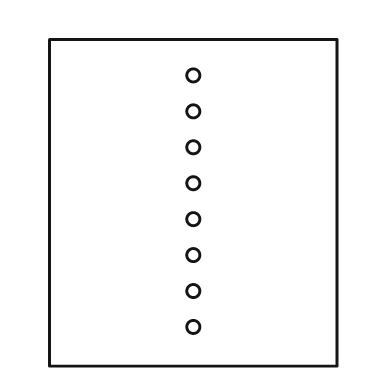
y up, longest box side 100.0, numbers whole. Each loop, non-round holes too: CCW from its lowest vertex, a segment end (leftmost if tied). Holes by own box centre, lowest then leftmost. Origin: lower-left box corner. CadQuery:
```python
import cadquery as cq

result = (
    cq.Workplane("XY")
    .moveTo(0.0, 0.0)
    .lineTo(88.0, 0.0)
    .lineTo(88.0, 100.0)
    .lineTo(0.0, 100.0)
    .close()
    .moveTo(44.0, 12.0)
    .circle(2.0)
    .moveTo(44.0, 23.0)
    .circle(2.0)
    .moveTo(44.0, 34.0)
    .circle(2.0)
    .moveTo(44.0, 45.0)
    .circle(2.0)
    .moveTo(44.0, 56.0)
    .circle(2.0)
    .moveTo(44.0, 67.0)
    .circle(2.0)
    .moveTo(44.0, 78.0)
    .circle(2.0)
    .moveTo(44.0, 89.0)
    .circle(2.0)
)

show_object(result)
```